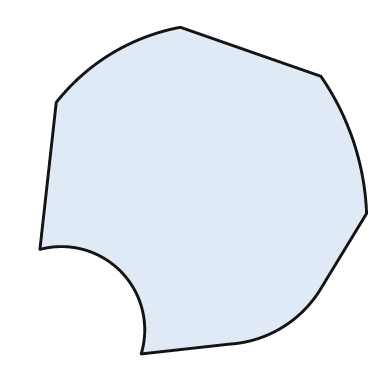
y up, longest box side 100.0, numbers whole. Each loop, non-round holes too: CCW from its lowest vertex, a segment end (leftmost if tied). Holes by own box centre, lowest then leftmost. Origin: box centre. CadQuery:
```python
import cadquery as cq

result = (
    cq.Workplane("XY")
    .moveTo(-19.0, -50.0)
    .lineTo(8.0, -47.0)
    .threePointArc((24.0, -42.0), (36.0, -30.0))
    .lineTo(50.0, -7.0)
    .threePointArc((46.0, 15.0), (36.0, 35.0))
    .lineTo(-7.0, 50.0)
    .threePointArc((-28.0, 42.0), (-45.0, 27.0))
    .lineTo(-50.0, -18.0)
    .threePointArc((-25.0, -25.0), (-19.0, -50.0))
    .close()
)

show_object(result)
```